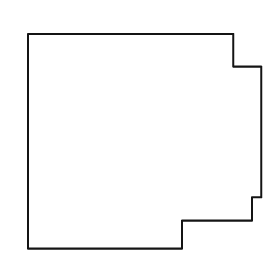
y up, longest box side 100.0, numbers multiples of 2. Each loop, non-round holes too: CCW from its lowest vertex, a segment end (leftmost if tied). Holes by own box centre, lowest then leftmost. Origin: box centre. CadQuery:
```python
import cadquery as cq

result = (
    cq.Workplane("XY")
    .moveTo(-50.0, -46.0)
    .lineTo(16.0, -46.0)
    .lineTo(16.0, -34.0)
    .lineTo(46.0, -34.0)
    .lineTo(46.0, -24.0)
    .lineTo(50.0, -24.0)
    .lineTo(50.0, 32.0)
    .lineTo(38.0, 32.0)
    .lineTo(38.0, 46.0)
    .lineTo(-50.0, 46.0)
    .close()
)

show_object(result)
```